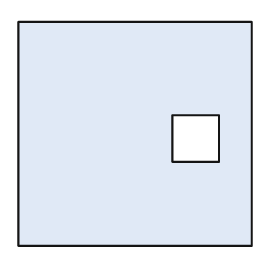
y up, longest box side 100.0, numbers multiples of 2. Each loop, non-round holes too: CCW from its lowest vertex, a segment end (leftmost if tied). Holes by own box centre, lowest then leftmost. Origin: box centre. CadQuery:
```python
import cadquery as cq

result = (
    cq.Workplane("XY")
    .moveTo(-50.0, -48.0)
    .lineTo(50.0, -48.0)
    .lineTo(50.0, 48.0)
    .lineTo(-50.0, 48.0)
    .close()
    .moveTo(16.0, -12.0)
    .lineTo(36.0, -12.0)
    .lineTo(36.0, 8.0)
    .lineTo(16.0, 8.0)
    .close()
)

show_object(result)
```